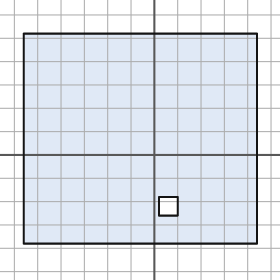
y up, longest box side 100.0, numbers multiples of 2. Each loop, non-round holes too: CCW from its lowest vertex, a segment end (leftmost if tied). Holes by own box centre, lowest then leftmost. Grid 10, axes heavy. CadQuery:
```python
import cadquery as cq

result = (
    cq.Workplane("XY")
    .moveTo(-56.0, -38.0)
    .lineTo(44.0, -38.0)
    .lineTo(44.0, 52.0)
    .lineTo(-56.0, 52.0)
    .close()
    .moveTo(2.0, -26.0)
    .lineTo(10.0, -26.0)
    .lineTo(10.0, -18.0)
    .lineTo(2.0, -18.0)
    .close()
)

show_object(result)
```